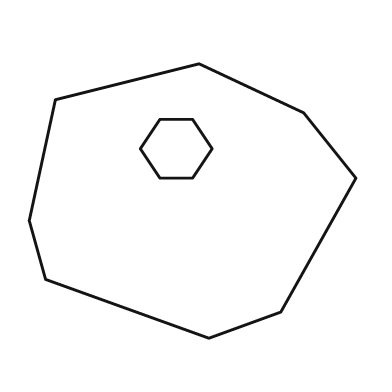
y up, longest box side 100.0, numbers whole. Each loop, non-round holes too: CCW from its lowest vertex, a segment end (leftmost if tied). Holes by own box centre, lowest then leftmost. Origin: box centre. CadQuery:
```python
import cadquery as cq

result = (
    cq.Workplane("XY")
    .moveTo(5.0, -42.0)
    .lineTo(27.0, -34.0)
    .lineTo(50.0, 7.0)
    .lineTo(34.0, 27.0)
    .lineTo(2.0, 42.0)
    .lineTo(-42.0, 31.0)
    .lineTo(-50.0, -6.0)
    .lineTo(-45.0, -24.0)
    .close()
    .moveTo(-10.0, 7.0)
    .lineTo(0.0, 7.0)
    .lineTo(6.0, 16.0)
    .lineTo(0.0, 25.0)
    .lineTo(-10.0, 25.0)
    .lineTo(-16.0, 16.0)
    .close()
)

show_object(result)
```